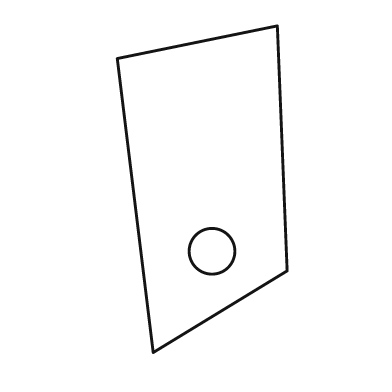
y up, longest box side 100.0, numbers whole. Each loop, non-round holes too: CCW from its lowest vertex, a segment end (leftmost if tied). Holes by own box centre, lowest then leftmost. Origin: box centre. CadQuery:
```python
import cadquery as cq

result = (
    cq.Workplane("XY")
    .moveTo(-15.0, -50.0)
    .lineTo(26.0, -25.0)
    .lineTo(23.0, 50.0)
    .lineTo(-26.0, 40.0)
    .close()
    .moveTo(3.0, -19.0)
    .circle(7.0)
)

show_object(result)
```